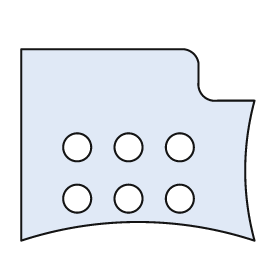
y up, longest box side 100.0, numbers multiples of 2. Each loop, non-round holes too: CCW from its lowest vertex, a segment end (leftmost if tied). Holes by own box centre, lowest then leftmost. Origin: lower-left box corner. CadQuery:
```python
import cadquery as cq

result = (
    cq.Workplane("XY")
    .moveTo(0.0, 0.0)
    .threePointArc((50.0, 8.0), (100.0, 0.0))
    .threePointArc((96.0, 30.0), (100.0, 60.0))
    .lineTo(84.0, 60.0)
    .threePointArc((78.0, 62.0), (76.0, 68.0))
    .lineTo(76.0, 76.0)
    .threePointArc((74.0, 80.0), (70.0, 82.0))
    .lineTo(0.0, 82.0)
    .close()
    .moveTo(24.0, 18.0)
    .circle(6.0)
    .moveTo(46.0, 18.0)
    .circle(6.0)
    .moveTo(68.0, 18.0)
    .circle(6.0)
    .moveTo(24.0, 40.0)
    .circle(6.0)
    .moveTo(46.0, 40.0)
    .circle(6.0)
    .moveTo(68.0, 40.0)
    .circle(6.0)
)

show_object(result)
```